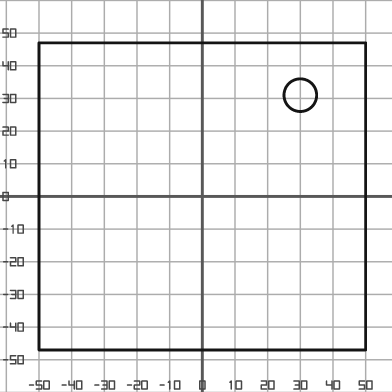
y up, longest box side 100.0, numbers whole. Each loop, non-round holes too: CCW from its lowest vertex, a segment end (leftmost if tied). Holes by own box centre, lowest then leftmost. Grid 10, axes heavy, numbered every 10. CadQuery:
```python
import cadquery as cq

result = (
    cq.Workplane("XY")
    .moveTo(-50.0, -47.0)
    .lineTo(50.0, -47.0)
    .lineTo(50.0, 47.0)
    .lineTo(-50.0, 47.0)
    .close()
    .moveTo(30.0, 31.0)
    .circle(5.0)
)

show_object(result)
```